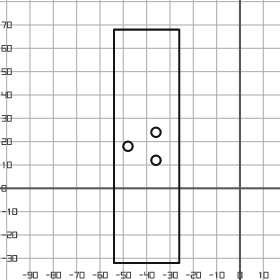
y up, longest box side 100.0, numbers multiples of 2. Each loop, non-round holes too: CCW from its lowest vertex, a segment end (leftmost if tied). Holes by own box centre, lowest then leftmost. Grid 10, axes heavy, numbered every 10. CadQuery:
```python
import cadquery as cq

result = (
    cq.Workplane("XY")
    .moveTo(-54.0, -32.0)
    .lineTo(-26.0, -32.0)
    .lineTo(-26.0, 68.0)
    .lineTo(-54.0, 68.0)
    .close()
    .moveTo(-36.0, 12.0)
    .circle(2.0)
    .moveTo(-48.0, 18.0)
    .circle(2.0)
    .moveTo(-36.0, 24.0)
    .circle(2.0)
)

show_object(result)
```